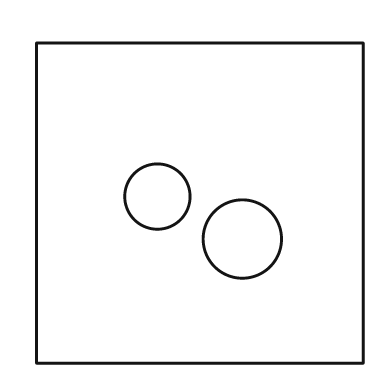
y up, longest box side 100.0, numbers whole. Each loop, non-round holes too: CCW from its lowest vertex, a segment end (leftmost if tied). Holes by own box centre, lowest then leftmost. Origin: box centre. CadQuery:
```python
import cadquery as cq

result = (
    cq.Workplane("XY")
    .moveTo(-50.0, -49.0)
    .lineTo(50.0, -49.0)
    .lineTo(50.0, 49.0)
    .lineTo(-50.0, 49.0)
    .close()
    .moveTo(13.0, -11.0)
    .circle(12.0)
    .moveTo(-13.0, 2.0)
    .circle(10.0)
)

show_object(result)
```